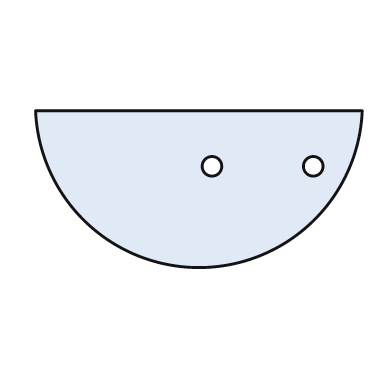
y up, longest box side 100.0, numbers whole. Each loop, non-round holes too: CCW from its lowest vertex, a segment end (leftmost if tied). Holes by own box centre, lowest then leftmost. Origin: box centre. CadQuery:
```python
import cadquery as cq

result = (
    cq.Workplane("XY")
    .moveTo(-50.0, 24.0)
    .threePointArc((0.0, -24.0), (50.0, 24.0))
    .close()
    .moveTo(4.0, 7.0)
    .circle(3.0)
    .moveTo(35.0, 7.0)
    .circle(3.0)
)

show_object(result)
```